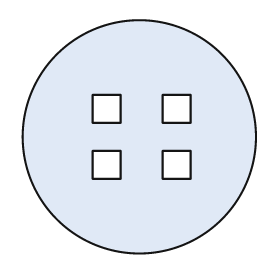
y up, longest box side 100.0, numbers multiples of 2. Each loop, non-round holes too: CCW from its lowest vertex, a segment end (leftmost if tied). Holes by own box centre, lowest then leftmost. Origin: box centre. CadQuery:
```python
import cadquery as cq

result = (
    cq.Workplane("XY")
    .moveTo(0.0, 0.0)
    .circle(50.0)
    .moveTo(-20.0, -18.0)
    .lineTo(-8.0, -18.0)
    .lineTo(-8.0, -6.0)
    .lineTo(-20.0, -6.0)
    .close()
    .moveTo(10.0, -18.0)
    .lineTo(22.0, -18.0)
    .lineTo(22.0, -6.0)
    .lineTo(10.0, -6.0)
    .close()
    .moveTo(-20.0, 6.0)
    .lineTo(-8.0, 6.0)
    .lineTo(-8.0, 18.0)
    .lineTo(-20.0, 18.0)
    .close()
    .moveTo(10.0, 6.0)
    .lineTo(22.0, 6.0)
    .lineTo(22.0, 18.0)
    .lineTo(10.0, 18.0)
    .close()
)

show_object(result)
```